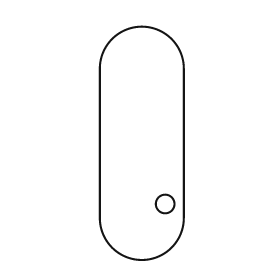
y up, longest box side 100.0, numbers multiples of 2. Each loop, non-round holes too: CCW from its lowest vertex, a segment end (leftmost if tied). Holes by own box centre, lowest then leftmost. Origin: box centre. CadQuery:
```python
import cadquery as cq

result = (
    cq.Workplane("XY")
    .moveTo(-18.0, -32.0)
    .threePointArc((0.0, -50.0), (18.0, -32.0))
    .lineTo(18.0, 32.0)
    .threePointArc((0.0, 50.0), (-18.0, 32.0))
    .close()
    .moveTo(10.0, -26.0)
    .circle(4.0)
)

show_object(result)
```